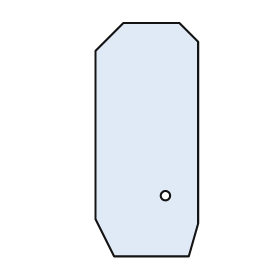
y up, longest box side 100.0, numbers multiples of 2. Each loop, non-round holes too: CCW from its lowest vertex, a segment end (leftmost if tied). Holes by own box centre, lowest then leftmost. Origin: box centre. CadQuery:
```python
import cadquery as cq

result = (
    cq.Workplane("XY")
    .moveTo(-14.0, -50.0)
    .lineTo(18.0, -50.0)
    .lineTo(22.0, -36.0)
    .lineTo(22.0, 42.0)
    .lineTo(14.0, 50.0)
    .lineTo(-10.0, 50.0)
    .lineTo(-22.0, 38.0)
    .lineTo(-22.0, -34.0)
    .close()
    .moveTo(8.0, -24.0)
    .circle(2.0)
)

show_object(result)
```